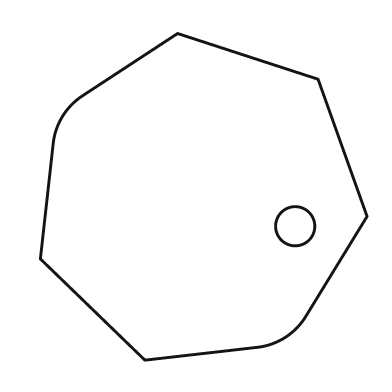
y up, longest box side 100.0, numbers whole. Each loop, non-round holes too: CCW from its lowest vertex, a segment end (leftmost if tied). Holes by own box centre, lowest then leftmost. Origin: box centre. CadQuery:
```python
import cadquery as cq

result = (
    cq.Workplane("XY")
    .moveTo(-18.0, -50.0)
    .lineTo(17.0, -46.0)
    .threePointArc((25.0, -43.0), (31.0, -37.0))
    .lineTo(50.0, -6.0)
    .lineTo(35.0, 36.0)
    .lineTo(-8.0, 50.0)
    .lineTo(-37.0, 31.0)
    .threePointArc((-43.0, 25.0), (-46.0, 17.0))
    .lineTo(-50.0, -19.0)
    .close()
    .moveTo(28.0, -9.0)
    .circle(6.0)
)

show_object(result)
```